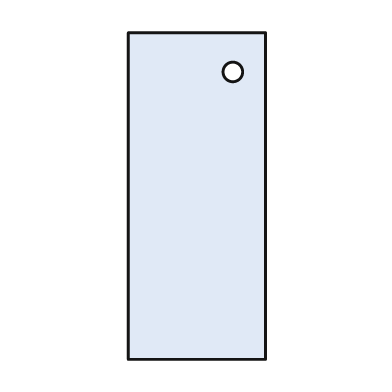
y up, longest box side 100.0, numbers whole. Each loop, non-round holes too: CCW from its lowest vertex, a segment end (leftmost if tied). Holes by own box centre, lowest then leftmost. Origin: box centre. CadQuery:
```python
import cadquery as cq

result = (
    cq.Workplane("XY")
    .moveTo(-21.0, -50.0)
    .lineTo(21.0, -50.0)
    .lineTo(21.0, 50.0)
    .lineTo(-21.0, 50.0)
    .close()
    .moveTo(11.0, 38.0)
    .circle(3.0)
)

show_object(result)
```